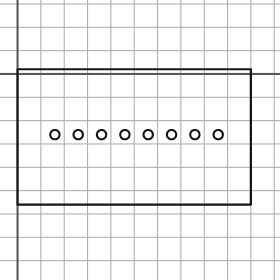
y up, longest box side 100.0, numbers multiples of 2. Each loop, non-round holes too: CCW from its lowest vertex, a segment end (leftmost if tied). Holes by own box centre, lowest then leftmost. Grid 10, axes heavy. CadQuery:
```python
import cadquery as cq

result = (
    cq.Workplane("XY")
    .moveTo(0.0, -56.0)
    .lineTo(100.0, -56.0)
    .lineTo(100.0, 2.0)
    .lineTo(0.0, 2.0)
    .close()
    .moveTo(16.0, -26.0)
    .circle(2.0)
    .moveTo(26.0, -26.0)
    .circle(2.0)
    .moveTo(36.0, -26.0)
    .circle(2.0)
    .moveTo(46.0, -26.0)
    .circle(2.0)
    .moveTo(56.0, -26.0)
    .circle(2.0)
    .moveTo(66.0, -26.0)
    .circle(2.0)
    .moveTo(76.0, -26.0)
    .circle(2.0)
    .moveTo(86.0, -26.0)
    .circle(2.0)
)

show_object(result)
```